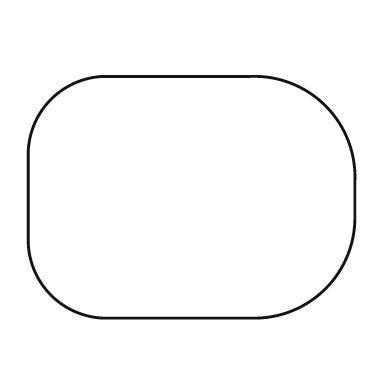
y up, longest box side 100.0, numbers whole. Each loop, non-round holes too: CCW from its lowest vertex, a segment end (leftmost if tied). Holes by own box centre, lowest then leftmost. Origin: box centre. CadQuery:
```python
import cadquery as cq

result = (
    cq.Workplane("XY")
    .moveTo(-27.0, -37.0)
    .lineTo(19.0, -37.0)
    .threePointArc((41.0, -28.0), (50.0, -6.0))
    .lineTo(50.0, 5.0)
    .threePointArc((41.0, 28.0), (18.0, 37.0))
    .lineTo(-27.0, 37.0)
    .threePointArc((-43.0, 30.0), (-50.0, 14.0))
    .lineTo(-50.0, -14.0)
    .threePointArc((-43.0, -30.0), (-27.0, -37.0))
    .close()
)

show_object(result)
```